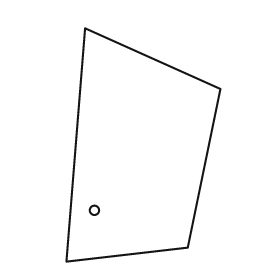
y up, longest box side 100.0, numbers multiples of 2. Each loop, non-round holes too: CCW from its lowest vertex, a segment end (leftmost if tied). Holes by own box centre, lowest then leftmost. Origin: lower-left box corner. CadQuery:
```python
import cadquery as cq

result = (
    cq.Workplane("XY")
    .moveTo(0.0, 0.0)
    .lineTo(52.0, 6.0)
    .lineTo(66.0, 74.0)
    .lineTo(8.0, 100.0)
    .close()
    .moveTo(12.0, 22.0)
    .circle(2.0)
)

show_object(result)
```